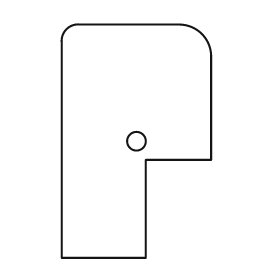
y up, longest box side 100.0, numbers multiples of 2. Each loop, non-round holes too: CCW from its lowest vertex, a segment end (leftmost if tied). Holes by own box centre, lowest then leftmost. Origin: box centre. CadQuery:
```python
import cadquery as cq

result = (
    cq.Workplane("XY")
    .moveTo(-32.0, -50.0)
    .lineTo(4.0, -50.0)
    .lineTo(4.0, -8.0)
    .lineTo(32.0, -8.0)
    .lineTo(32.0, 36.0)
    .threePointArc((28.0, 46.0), (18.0, 50.0))
    .lineTo(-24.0, 50.0)
    .threePointArc((-30.0, 48.0), (-32.0, 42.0))
    .close()
    .moveTo(0.0, 0.0)
    .circle(4.0)
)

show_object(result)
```